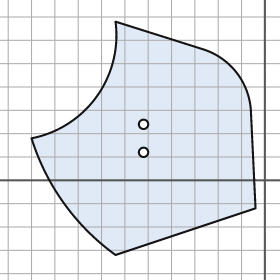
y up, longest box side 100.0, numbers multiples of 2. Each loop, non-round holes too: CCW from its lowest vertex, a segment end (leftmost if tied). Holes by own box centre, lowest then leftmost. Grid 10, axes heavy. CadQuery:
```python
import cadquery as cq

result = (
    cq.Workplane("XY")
    .moveTo(-64.0, -32.0)
    .lineTo(-4.0, -12.0)
    .lineTo(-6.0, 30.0)
    .threePointArc((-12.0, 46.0), (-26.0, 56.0))
    .lineTo(-64.0, 68.0)
    .threePointArc((-72.0, 36.0), (-100.0, 18.0))
    .threePointArc((-86.0, -10.0), (-64.0, -32.0))
    .close()
    .moveTo(-52.0, 12.0)
    .circle(2.0)
    .moveTo(-52.0, 24.0)
    .circle(2.0)
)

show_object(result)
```